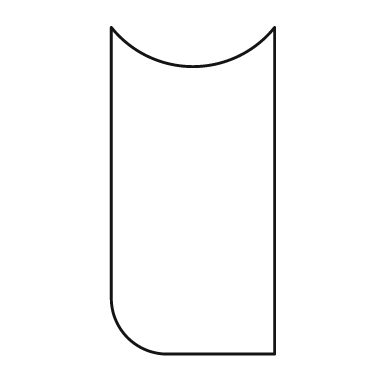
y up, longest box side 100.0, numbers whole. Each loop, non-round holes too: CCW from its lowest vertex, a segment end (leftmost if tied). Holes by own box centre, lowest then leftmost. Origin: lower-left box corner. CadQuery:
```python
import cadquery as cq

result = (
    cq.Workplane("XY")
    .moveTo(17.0, 0.0)
    .lineTo(50.0, 0.0)
    .lineTo(50.0, 100.0)
    .threePointArc((25.0, 88.0), (0.0, 100.0))
    .lineTo(0.0, 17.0)
    .threePointArc((5.0, 5.0), (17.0, 0.0))
    .close()
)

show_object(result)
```